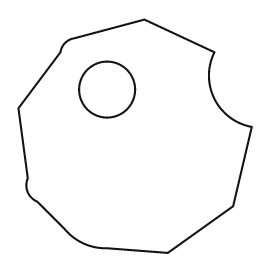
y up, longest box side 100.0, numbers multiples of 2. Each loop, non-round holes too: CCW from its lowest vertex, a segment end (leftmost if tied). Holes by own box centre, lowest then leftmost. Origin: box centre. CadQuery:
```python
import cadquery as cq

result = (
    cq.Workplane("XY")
    .moveTo(14.0, -50.0)
    .lineTo(42.0, -30.0)
    .lineTo(50.0, 4.0)
    .threePointArc((34.0, 16.0), (34.0, 36.0))
    .lineTo(4.0, 50.0)
    .lineTo(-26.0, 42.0)
    .threePointArc((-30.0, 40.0), (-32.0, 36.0))
    .lineTo(-50.0, 12.0)
    .lineTo(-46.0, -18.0)
    .threePointArc((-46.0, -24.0), (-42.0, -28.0))
    .lineTo(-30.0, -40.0)
    .threePointArc((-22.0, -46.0), (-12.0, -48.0))
    .close()
    .moveTo(-12.0, 20.0)
    .circle(12.0)
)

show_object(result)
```